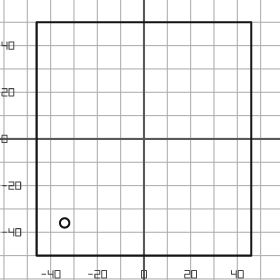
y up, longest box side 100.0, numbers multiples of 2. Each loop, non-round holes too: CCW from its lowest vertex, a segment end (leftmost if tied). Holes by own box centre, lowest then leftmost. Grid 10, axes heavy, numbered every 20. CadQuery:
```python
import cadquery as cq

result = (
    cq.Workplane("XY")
    .moveTo(-46.0, -50.0)
    .lineTo(46.0, -50.0)
    .lineTo(46.0, 50.0)
    .lineTo(-46.0, 50.0)
    .close()
    .moveTo(-34.0, -36.0)
    .circle(2.0)
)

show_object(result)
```